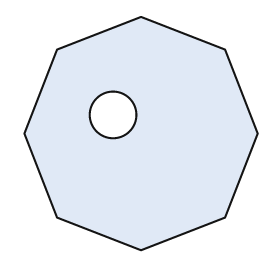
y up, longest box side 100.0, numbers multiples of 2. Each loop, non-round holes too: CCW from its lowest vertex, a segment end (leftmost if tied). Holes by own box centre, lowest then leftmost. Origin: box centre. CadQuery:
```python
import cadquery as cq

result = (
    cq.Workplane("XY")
    .moveTo(0.0, -50.0)
    .lineTo(36.0, -36.0)
    .lineTo(50.0, 0.0)
    .lineTo(36.0, 36.0)
    .lineTo(0.0, 50.0)
    .lineTo(-36.0, 36.0)
    .lineTo(-50.0, 0.0)
    .lineTo(-36.0, -36.0)
    .close()
    .moveTo(-12.0, 8.0)
    .circle(10.0)
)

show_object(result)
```